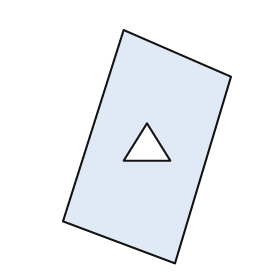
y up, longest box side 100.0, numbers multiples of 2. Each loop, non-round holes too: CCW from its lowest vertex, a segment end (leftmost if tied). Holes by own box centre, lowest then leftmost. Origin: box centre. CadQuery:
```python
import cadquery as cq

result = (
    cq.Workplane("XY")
    .moveTo(12.0, -50.0)
    .lineTo(36.0, 30.0)
    .lineTo(-10.0, 50.0)
    .lineTo(-36.0, -32.0)
    .close()
    .moveTo(-10.0, -6.0)
    .lineTo(10.0, -6.0)
    .lineTo(0.0, 10.0)
    .close()
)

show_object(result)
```